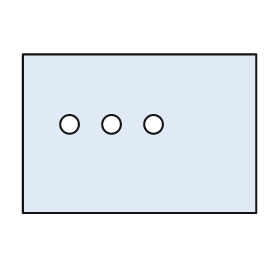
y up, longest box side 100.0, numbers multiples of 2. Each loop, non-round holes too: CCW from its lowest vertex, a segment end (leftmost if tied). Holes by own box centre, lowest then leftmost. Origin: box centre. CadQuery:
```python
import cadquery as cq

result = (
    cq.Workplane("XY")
    .moveTo(-50.0, -34.0)
    .lineTo(50.0, -34.0)
    .lineTo(50.0, 34.0)
    .lineTo(-50.0, 34.0)
    .close()
    .moveTo(-30.0, 4.0)
    .circle(4.0)
    .moveTo(-12.0, 4.0)
    .circle(4.0)
    .moveTo(6.0, 4.0)
    .circle(4.0)
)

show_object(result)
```